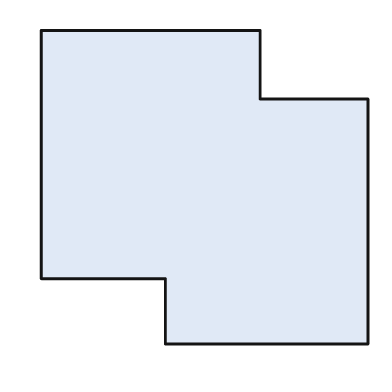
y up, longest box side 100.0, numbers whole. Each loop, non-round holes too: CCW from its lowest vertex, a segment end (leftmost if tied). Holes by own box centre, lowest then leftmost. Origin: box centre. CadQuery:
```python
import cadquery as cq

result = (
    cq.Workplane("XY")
    .moveTo(-12.0, -48.0)
    .lineTo(50.0, -48.0)
    .lineTo(50.0, 27.0)
    .lineTo(17.0, 27.0)
    .lineTo(17.0, 48.0)
    .lineTo(-50.0, 48.0)
    .lineTo(-50.0, -28.0)
    .lineTo(-12.0, -28.0)
    .close()
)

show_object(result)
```